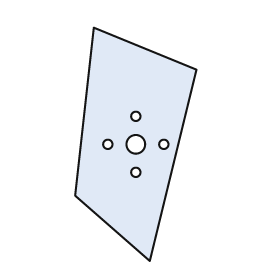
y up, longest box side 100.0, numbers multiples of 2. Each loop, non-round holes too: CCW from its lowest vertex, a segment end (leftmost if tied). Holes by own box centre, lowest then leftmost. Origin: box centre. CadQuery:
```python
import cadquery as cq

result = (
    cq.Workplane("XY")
    .moveTo(6.0, -50.0)
    .lineTo(26.0, 32.0)
    .lineTo(-18.0, 50.0)
    .lineTo(-26.0, -22.0)
    .close()
    .moveTo(0.0, -12.0)
    .circle(2.0)
    .moveTo(-12.0, 0.0)
    .circle(2.0)
    .moveTo(0.0, 0.0)
    .circle(4.0)
    .moveTo(12.0, 0.0)
    .circle(2.0)
    .moveTo(0.0, 12.0)
    .circle(2.0)
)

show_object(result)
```